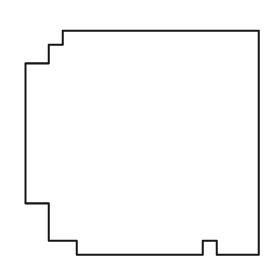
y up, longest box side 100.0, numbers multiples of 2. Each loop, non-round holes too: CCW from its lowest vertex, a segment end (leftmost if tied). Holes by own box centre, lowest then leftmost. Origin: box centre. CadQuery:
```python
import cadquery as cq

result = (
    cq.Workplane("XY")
    .moveTo(-28.0, -48.0)
    .lineTo(26.0, -48.0)
    .lineTo(26.0, -42.0)
    .lineTo(32.0, -42.0)
    .lineTo(32.0, -48.0)
    .lineTo(50.0, -48.0)
    .lineTo(50.0, 48.0)
    .lineTo(-34.0, 48.0)
    .lineTo(-34.0, 42.0)
    .lineTo(-40.0, 42.0)
    .lineTo(-40.0, 34.0)
    .lineTo(-50.0, 34.0)
    .lineTo(-50.0, -26.0)
    .lineTo(-40.0, -26.0)
    .lineTo(-40.0, -42.0)
    .lineTo(-28.0, -42.0)
    .close()
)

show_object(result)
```